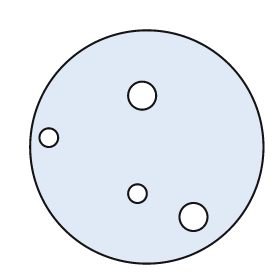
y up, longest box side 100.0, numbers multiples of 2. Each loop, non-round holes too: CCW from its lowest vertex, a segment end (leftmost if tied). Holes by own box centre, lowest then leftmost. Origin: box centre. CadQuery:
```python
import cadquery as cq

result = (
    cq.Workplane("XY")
    .moveTo(0.0, 0.0)
    .circle(50.0)
    .moveTo(20.0, -30.0)
    .circle(6.0)
    .moveTo(-4.0, -20.0)
    .circle(4.0)
    .moveTo(-42.0, 4.0)
    .circle(4.0)
    .moveTo(-2.0, 22.0)
    .circle(6.0)
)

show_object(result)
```